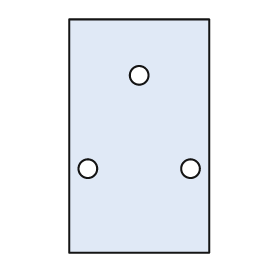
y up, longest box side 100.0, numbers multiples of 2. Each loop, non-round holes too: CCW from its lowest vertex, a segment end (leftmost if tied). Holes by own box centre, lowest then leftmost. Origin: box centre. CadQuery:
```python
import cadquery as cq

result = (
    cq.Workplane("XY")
    .moveTo(-30.0, -50.0)
    .lineTo(30.0, -50.0)
    .lineTo(30.0, 50.0)
    .lineTo(-30.0, 50.0)
    .close()
    .moveTo(-22.0, -14.0)
    .circle(4.0)
    .moveTo(22.0, -14.0)
    .circle(4.0)
    .moveTo(0.0, 26.0)
    .circle(4.0)
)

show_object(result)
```